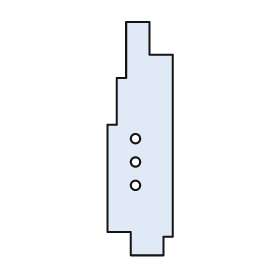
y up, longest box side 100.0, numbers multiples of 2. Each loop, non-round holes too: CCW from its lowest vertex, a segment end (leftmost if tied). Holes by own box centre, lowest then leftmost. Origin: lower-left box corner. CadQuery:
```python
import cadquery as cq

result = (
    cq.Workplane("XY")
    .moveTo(10.0, 0.0)
    .lineTo(24.0, 0.0)
    .lineTo(24.0, 8.0)
    .lineTo(28.0, 8.0)
    .lineTo(28.0, 86.0)
    .lineTo(18.0, 86.0)
    .lineTo(18.0, 100.0)
    .lineTo(8.0, 100.0)
    .lineTo(8.0, 76.0)
    .lineTo(4.0, 76.0)
    .lineTo(4.0, 56.0)
    .lineTo(0.0, 56.0)
    .lineTo(0.0, 10.0)
    .lineTo(10.0, 10.0)
    .close()
    .moveTo(12.0, 30.0)
    .circle(2.0)
    .moveTo(12.0, 40.0)
    .circle(2.0)
    .moveTo(12.0, 50.0)
    .circle(2.0)
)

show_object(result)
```